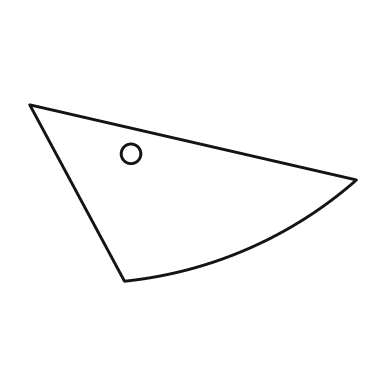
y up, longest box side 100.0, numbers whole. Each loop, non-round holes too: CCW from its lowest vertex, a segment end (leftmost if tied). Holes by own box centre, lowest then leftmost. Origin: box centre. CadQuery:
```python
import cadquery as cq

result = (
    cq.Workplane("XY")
    .moveTo(-21.0, -27.0)
    .threePointArc((17.0, -17.0), (50.0, 4.0))
    .lineTo(-50.0, 27.0)
    .close()
    .moveTo(-19.0, 12.0)
    .circle(3.0)
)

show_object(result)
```